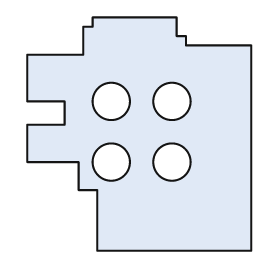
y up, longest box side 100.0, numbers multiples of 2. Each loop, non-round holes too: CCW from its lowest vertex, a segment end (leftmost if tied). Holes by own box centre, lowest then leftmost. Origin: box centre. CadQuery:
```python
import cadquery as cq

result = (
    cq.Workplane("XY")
    .moveTo(-18.0, -50.0)
    .lineTo(48.0, -50.0)
    .lineTo(48.0, 38.0)
    .lineTo(20.0, 38.0)
    .lineTo(20.0, 42.0)
    .lineTo(16.0, 42.0)
    .lineTo(16.0, 50.0)
    .lineTo(-20.0, 50.0)
    .lineTo(-20.0, 46.0)
    .lineTo(-24.0, 46.0)
    .lineTo(-24.0, 34.0)
    .lineTo(-48.0, 34.0)
    .lineTo(-48.0, 14.0)
    .lineTo(-32.0, 14.0)
    .lineTo(-32.0, 4.0)
    .lineTo(-48.0, 4.0)
    .lineTo(-48.0, -12.0)
    .lineTo(-26.0, -12.0)
    .lineTo(-26.0, -24.0)
    .lineTo(-18.0, -24.0)
    .close()
    .moveTo(-12.0, -12.0)
    .circle(8.0)
    .moveTo(14.0, -12.0)
    .circle(8.0)
    .moveTo(-12.0, 14.0)
    .circle(8.0)
    .moveTo(14.0, 14.0)
    .circle(8.0)
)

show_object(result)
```